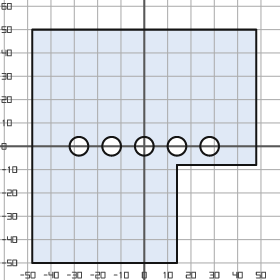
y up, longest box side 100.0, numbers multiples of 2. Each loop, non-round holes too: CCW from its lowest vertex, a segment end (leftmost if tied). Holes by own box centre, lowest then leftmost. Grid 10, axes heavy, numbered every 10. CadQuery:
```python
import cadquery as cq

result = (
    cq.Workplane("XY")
    .moveTo(-48.0, -50.0)
    .lineTo(14.0, -50.0)
    .lineTo(14.0, -8.0)
    .lineTo(48.0, -8.0)
    .lineTo(48.0, 50.0)
    .lineTo(-48.0, 50.0)
    .close()
    .moveTo(-28.0, 0.0)
    .circle(4.0)
    .moveTo(-14.0, 0.0)
    .circle(4.0)
    .moveTo(0.0, 0.0)
    .circle(4.0)
    .moveTo(14.0, 0.0)
    .circle(4.0)
    .moveTo(28.0, 0.0)
    .circle(4.0)
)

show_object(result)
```